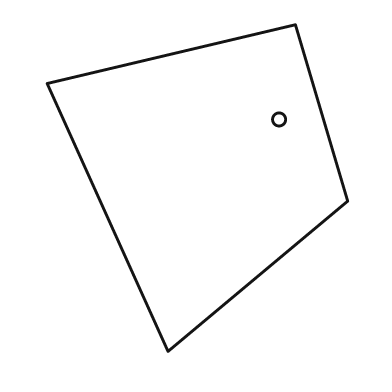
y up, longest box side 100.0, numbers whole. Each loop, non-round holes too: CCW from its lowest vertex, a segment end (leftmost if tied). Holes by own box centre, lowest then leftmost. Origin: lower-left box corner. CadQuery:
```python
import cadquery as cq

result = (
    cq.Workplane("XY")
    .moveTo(37.0, 0.0)
    .lineTo(92.0, 46.0)
    .lineTo(76.0, 100.0)
    .lineTo(0.0, 82.0)
    .close()
    .moveTo(71.0, 71.0)
    .circle(2.0)
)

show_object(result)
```